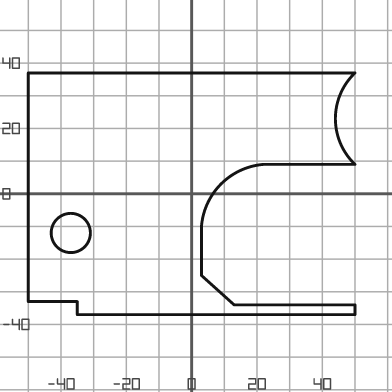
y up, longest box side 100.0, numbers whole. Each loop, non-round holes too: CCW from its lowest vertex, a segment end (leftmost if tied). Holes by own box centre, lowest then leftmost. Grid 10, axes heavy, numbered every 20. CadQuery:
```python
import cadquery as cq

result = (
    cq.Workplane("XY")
    .moveTo(-35.0, -37.0)
    .lineTo(50.0, -37.0)
    .lineTo(50.0, -34.0)
    .lineTo(13.0, -34.0)
    .lineTo(3.0, -25.0)
    .lineTo(3.0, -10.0)
    .threePointArc((9.0, 3.0), (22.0, 9.0))
    .lineTo(50.0, 9.0)
    .threePointArc((44.0, 23.0), (50.0, 37.0))
    .lineTo(-50.0, 37.0)
    .lineTo(-50.0, -33.0)
    .lineTo(-35.0, -33.0)
    .close()
    .moveTo(-37.0, -12.0)
    .circle(6.0)
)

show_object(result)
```